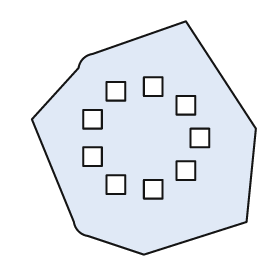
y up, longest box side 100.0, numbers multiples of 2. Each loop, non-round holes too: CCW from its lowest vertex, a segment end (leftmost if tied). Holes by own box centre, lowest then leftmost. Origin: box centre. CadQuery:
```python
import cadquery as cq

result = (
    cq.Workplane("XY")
    .moveTo(0.0, -50.0)
    .lineTo(44.0, -36.0)
    .lineTo(48.0, 4.0)
    .lineTo(18.0, 50.0)
    .lineTo(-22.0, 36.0)
    .threePointArc((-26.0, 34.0), (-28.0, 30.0))
    .lineTo(-48.0, 8.0)
    .lineTo(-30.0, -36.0)
    .threePointArc((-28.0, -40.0), (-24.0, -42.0))
    .close()
    .moveTo(0.0, -26.0)
    .lineTo(8.0, -26.0)
    .lineTo(8.0, -18.0)
    .lineTo(0.0, -18.0)
    .close()
    .moveTo(-16.0, -24.0)
    .lineTo(-8.0, -24.0)
    .lineTo(-8.0, -16.0)
    .lineTo(-16.0, -16.0)
    .close()
    .moveTo(14.0, -18.0)
    .lineTo(22.0, -18.0)
    .lineTo(22.0, -10.0)
    .lineTo(14.0, -10.0)
    .close()
    .moveTo(-26.0, -12.0)
    .lineTo(-18.0, -12.0)
    .lineTo(-18.0, -4.0)
    .lineTo(-26.0, -4.0)
    .close()
    .moveTo(20.0, -4.0)
    .lineTo(28.0, -4.0)
    .lineTo(28.0, 4.0)
    .lineTo(20.0, 4.0)
    .close()
    .moveTo(-26.0, 4.0)
    .lineTo(-18.0, 4.0)
    .lineTo(-18.0, 12.0)
    .lineTo(-26.0, 12.0)
    .close()
    .moveTo(14.0, 10.0)
    .lineTo(22.0, 10.0)
    .lineTo(22.0, 18.0)
    .lineTo(14.0, 18.0)
    .close()
    .moveTo(-16.0, 16.0)
    .lineTo(-8.0, 16.0)
    .lineTo(-8.0, 24.0)
    .lineTo(-16.0, 24.0)
    .close()
    .moveTo(0.0, 18.0)
    .lineTo(8.0, 18.0)
    .lineTo(8.0, 26.0)
    .lineTo(0.0, 26.0)
    .close()
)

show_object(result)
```